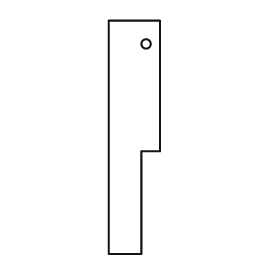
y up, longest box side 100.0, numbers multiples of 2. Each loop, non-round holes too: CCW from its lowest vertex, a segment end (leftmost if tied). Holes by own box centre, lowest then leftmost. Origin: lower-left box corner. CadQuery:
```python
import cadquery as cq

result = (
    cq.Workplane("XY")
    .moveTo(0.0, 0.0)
    .lineTo(14.0, 0.0)
    .lineTo(14.0, 44.0)
    .lineTo(22.0, 44.0)
    .lineTo(22.0, 100.0)
    .lineTo(0.0, 100.0)
    .close()
    .moveTo(16.0, 90.0)
    .circle(2.0)
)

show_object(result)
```